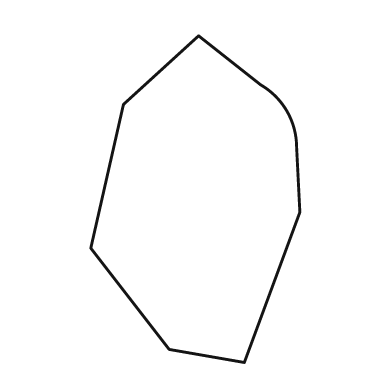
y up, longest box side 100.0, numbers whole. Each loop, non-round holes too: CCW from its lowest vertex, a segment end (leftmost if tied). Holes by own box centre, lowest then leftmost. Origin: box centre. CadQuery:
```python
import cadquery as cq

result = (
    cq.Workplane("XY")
    .moveTo(15.0, -50.0)
    .lineTo(32.0, -4.0)
    .lineTo(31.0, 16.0)
    .threePointArc((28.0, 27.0), (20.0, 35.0))
    .lineTo(1.0, 50.0)
    .lineTo(-22.0, 29.0)
    .lineTo(-32.0, -15.0)
    .lineTo(-8.0, -46.0)
    .close()
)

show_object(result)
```